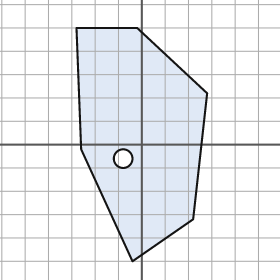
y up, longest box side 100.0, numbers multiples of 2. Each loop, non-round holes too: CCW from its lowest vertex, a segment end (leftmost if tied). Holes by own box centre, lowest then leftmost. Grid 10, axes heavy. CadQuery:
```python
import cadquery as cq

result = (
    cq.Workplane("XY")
    .moveTo(-4.0, -50.0)
    .lineTo(22.0, -32.0)
    .lineTo(28.0, 22.0)
    .lineTo(-2.0, 50.0)
    .lineTo(-28.0, 50.0)
    .lineTo(-26.0, -2.0)
    .close()
    .moveTo(-8.0, -6.0)
    .circle(4.0)
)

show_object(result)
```